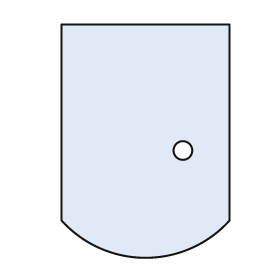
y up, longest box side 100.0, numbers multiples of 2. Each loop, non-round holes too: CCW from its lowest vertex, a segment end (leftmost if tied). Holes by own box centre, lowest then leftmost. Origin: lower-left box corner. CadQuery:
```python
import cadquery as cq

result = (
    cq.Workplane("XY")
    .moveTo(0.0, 16.0)
    .threePointArc((36.0, 0.0), (72.0, 16.0))
    .lineTo(72.0, 100.0)
    .lineTo(0.0, 100.0)
    .close()
    .moveTo(52.0, 46.0)
    .circle(4.0)
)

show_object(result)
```